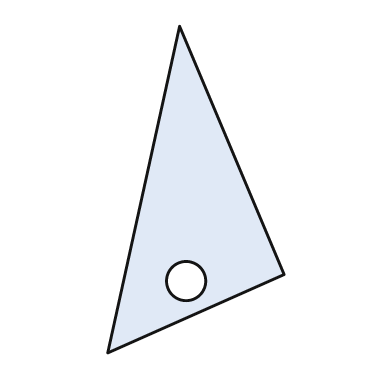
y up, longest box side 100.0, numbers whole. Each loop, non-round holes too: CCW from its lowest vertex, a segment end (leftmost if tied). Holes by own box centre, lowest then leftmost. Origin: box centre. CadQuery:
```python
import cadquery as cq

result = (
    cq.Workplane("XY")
    .moveTo(-27.0, -50.0)
    .lineTo(27.0, -26.0)
    .lineTo(-5.0, 50.0)
    .close()
    .moveTo(-3.0, -28.0)
    .circle(6.0)
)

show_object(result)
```